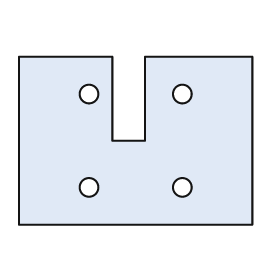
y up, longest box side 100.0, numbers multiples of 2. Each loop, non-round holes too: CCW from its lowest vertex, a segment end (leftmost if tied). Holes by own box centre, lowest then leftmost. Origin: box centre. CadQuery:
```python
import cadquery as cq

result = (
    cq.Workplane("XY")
    .moveTo(-50.0, -36.0)
    .lineTo(50.0, -36.0)
    .lineTo(50.0, 36.0)
    .lineTo(4.0, 36.0)
    .lineTo(4.0, 0.0)
    .lineTo(-10.0, 0.0)
    .lineTo(-10.0, 36.0)
    .lineTo(-50.0, 36.0)
    .close()
    .moveTo(-20.0, -20.0)
    .circle(4.0)
    .moveTo(20.0, -20.0)
    .circle(4.0)
    .moveTo(-20.0, 20.0)
    .circle(4.0)
    .moveTo(20.0, 20.0)
    .circle(4.0)
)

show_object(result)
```